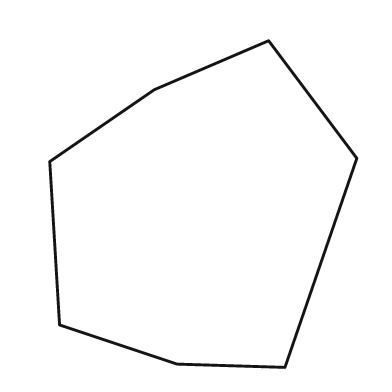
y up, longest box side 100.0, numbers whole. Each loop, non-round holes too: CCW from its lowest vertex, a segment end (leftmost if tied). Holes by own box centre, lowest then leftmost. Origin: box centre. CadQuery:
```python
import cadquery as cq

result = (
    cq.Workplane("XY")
    .moveTo(25.0, -50.0)
    .lineTo(47.0, 14.0)
    .lineTo(20.0, 50.0)
    .lineTo(-15.0, 35.0)
    .lineTo(-47.0, 13.0)
    .lineTo(-44.0, -37.0)
    .lineTo(-8.0, -49.0)
    .close()
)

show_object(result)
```